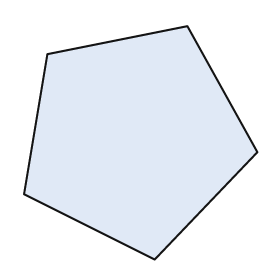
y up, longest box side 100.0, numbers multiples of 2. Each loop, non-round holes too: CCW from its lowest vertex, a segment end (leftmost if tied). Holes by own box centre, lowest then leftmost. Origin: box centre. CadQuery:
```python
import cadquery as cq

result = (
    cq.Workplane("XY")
    .moveTo(6.0, -50.0)
    .lineTo(50.0, -4.0)
    .lineTo(20.0, 50.0)
    .lineTo(-40.0, 38.0)
    .lineTo(-50.0, -22.0)
    .close()
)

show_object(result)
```